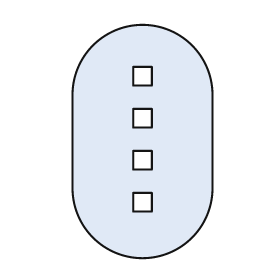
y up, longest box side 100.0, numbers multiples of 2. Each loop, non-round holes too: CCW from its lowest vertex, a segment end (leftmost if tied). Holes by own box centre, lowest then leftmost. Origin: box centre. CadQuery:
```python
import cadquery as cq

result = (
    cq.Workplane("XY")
    .moveTo(-30.0, -20.0)
    .threePointArc((0.0, -50.0), (30.0, -20.0))
    .lineTo(30.0, 20.0)
    .threePointArc((0.0, 50.0), (-30.0, 20.0))
    .close()
    .moveTo(-4.0, -30.0)
    .lineTo(4.0, -30.0)
    .lineTo(4.0, -22.0)
    .lineTo(-4.0, -22.0)
    .close()
    .moveTo(-4.0, -12.0)
    .lineTo(4.0, -12.0)
    .lineTo(4.0, -4.0)
    .lineTo(-4.0, -4.0)
    .close()
    .moveTo(-4.0, 6.0)
    .lineTo(4.0, 6.0)
    .lineTo(4.0, 14.0)
    .lineTo(-4.0, 14.0)
    .close()
    .moveTo(-4.0, 24.0)
    .lineTo(4.0, 24.0)
    .lineTo(4.0, 32.0)
    .lineTo(-4.0, 32.0)
    .close()
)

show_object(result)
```